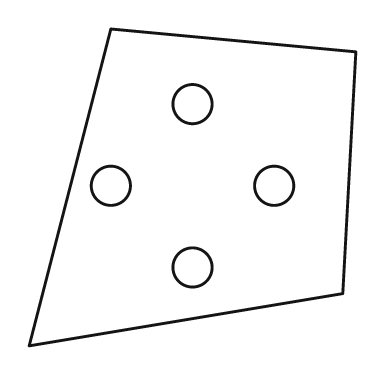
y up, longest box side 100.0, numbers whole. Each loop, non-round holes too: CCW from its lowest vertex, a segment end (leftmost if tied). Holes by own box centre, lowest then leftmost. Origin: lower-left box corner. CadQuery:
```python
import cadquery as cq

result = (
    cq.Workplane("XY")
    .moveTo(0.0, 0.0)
    .lineTo(96.0, 16.0)
    .lineTo(100.0, 90.0)
    .lineTo(25.0, 97.0)
    .close()
    .moveTo(50.0, 24.0)
    .circle(6.0)
    .moveTo(25.0, 49.0)
    .circle(6.0)
    .moveTo(75.0, 49.0)
    .circle(6.0)
    .moveTo(50.0, 74.0)
    .circle(6.0)
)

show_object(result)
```